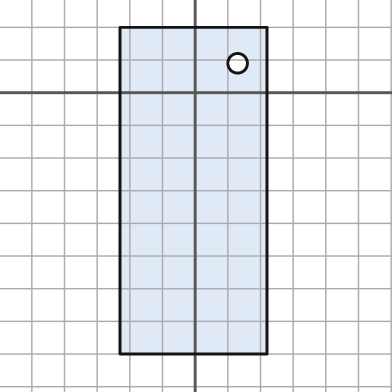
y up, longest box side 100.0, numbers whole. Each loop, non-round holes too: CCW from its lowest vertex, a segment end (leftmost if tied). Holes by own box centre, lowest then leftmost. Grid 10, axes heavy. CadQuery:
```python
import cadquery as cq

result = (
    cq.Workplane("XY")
    .moveTo(-23.0, -80.0)
    .lineTo(22.0, -80.0)
    .lineTo(22.0, 20.0)
    .lineTo(-23.0, 20.0)
    .close()
    .moveTo(13.0, 9.0)
    .circle(3.0)
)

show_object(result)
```